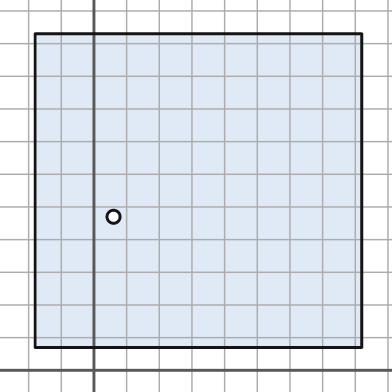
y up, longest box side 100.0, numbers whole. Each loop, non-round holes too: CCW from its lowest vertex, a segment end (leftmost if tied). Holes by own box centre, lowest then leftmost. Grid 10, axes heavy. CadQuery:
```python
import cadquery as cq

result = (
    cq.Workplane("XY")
    .moveTo(-18.0, 7.0)
    .lineTo(82.0, 7.0)
    .lineTo(82.0, 103.0)
    .lineTo(-18.0, 103.0)
    .close()
    .moveTo(6.0, 47.0)
    .circle(2.0)
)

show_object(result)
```